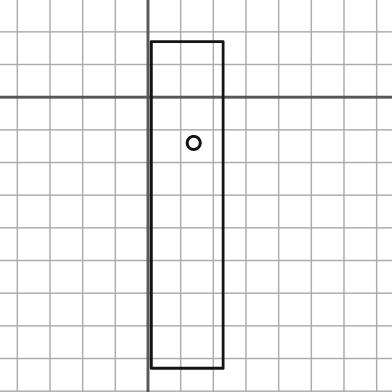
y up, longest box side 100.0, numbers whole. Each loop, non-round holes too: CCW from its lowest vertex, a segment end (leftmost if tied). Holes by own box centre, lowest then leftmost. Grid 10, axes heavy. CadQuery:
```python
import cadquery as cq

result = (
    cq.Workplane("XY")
    .moveTo(1.0, -83.0)
    .lineTo(23.0, -83.0)
    .lineTo(23.0, 17.0)
    .lineTo(1.0, 17.0)
    .close()
    .moveTo(14.0, -14.0)
    .circle(2.0)
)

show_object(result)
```